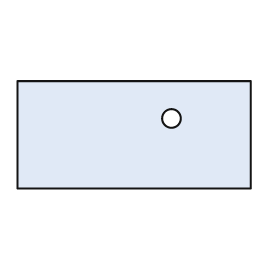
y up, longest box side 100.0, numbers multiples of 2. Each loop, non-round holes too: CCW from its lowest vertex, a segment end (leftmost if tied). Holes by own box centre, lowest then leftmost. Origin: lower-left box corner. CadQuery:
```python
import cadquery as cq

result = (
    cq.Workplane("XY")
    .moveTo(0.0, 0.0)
    .lineTo(100.0, 0.0)
    .lineTo(100.0, 46.0)
    .lineTo(0.0, 46.0)
    .close()
    .moveTo(66.0, 30.0)
    .circle(4.0)
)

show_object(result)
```